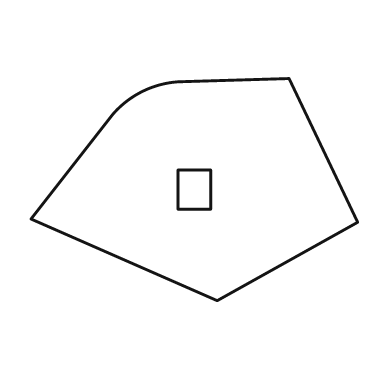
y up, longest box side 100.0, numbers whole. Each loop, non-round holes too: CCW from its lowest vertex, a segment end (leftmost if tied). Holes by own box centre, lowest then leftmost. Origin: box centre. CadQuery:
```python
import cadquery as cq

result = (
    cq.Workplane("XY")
    .moveTo(7.0, -34.0)
    .lineTo(50.0, -10.0)
    .lineTo(29.0, 34.0)
    .lineTo(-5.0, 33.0)
    .threePointArc((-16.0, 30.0), (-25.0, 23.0))
    .lineTo(-50.0, -9.0)
    .close()
    .moveTo(-5.0, -6.0)
    .lineTo(5.0, -6.0)
    .lineTo(5.0, 6.0)
    .lineTo(-5.0, 6.0)
    .close()
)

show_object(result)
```